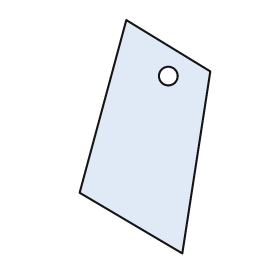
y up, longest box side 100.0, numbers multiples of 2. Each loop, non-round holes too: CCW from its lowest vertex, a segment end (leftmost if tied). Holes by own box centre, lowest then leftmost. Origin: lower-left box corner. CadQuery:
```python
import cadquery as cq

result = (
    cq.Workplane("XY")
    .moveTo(44.0, 0.0)
    .lineTo(56.0, 78.0)
    .lineTo(20.0, 100.0)
    .lineTo(0.0, 26.0)
    .close()
    .moveTo(38.0, 76.0)
    .circle(4.0)
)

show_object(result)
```